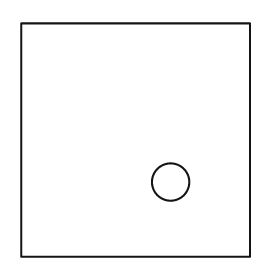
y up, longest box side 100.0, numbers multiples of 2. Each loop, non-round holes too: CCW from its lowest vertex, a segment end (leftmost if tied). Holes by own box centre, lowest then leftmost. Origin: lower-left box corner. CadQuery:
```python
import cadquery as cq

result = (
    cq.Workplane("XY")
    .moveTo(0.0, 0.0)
    .lineTo(98.0, 0.0)
    .lineTo(98.0, 100.0)
    .lineTo(0.0, 100.0)
    .close()
    .moveTo(64.0, 32.0)
    .circle(8.0)
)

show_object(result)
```